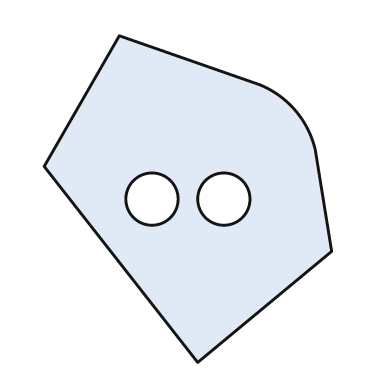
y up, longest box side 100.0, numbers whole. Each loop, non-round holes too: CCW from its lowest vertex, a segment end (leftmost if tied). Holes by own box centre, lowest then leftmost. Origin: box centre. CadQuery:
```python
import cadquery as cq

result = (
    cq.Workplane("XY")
    .moveTo(3.0, -50.0)
    .lineTo(44.0, -16.0)
    .lineTo(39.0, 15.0)
    .threePointArc((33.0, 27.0), (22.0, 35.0))
    .lineTo(-21.0, 50.0)
    .lineTo(-44.0, 10.0)
    .close()
    .moveTo(-11.0, 0.0)
    .circle(8.0)
    .moveTo(11.0, 0.0)
    .circle(8.0)
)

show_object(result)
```